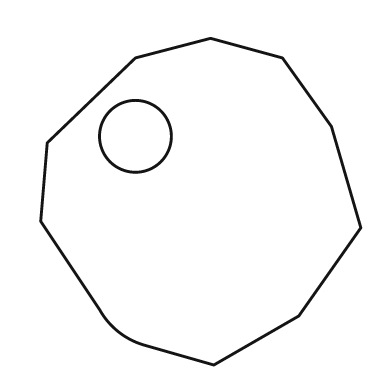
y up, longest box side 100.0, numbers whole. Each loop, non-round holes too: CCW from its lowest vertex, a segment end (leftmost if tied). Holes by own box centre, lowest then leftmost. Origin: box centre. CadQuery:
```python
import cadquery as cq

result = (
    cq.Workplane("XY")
    .moveTo(4.0, -50.0)
    .lineTo(30.0, -35.0)
    .lineTo(49.0, -8.0)
    .lineTo(40.0, 23.0)
    .lineTo(25.0, 44.0)
    .lineTo(3.0, 50.0)
    .lineTo(-20.0, 44.0)
    .lineTo(-47.0, 18.0)
    .lineTo(-49.0, -6.0)
    .lineTo(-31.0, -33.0)
    .threePointArc((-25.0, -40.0), (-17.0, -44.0))
    .close()
    .moveTo(-20.0, 20.0)
    .circle(11.0)
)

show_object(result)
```